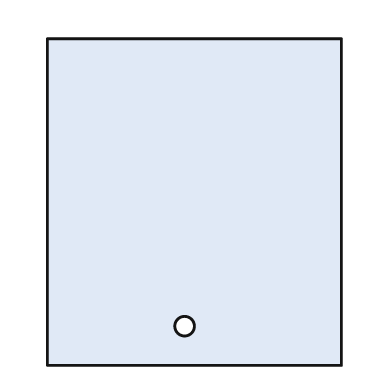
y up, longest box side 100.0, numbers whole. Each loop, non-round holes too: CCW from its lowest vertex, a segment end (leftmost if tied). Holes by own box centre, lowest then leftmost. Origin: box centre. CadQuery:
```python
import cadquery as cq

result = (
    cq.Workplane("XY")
    .moveTo(-45.0, -50.0)
    .lineTo(45.0, -50.0)
    .lineTo(45.0, 50.0)
    .lineTo(-45.0, 50.0)
    .close()
    .moveTo(-3.0, -38.0)
    .circle(3.0)
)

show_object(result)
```